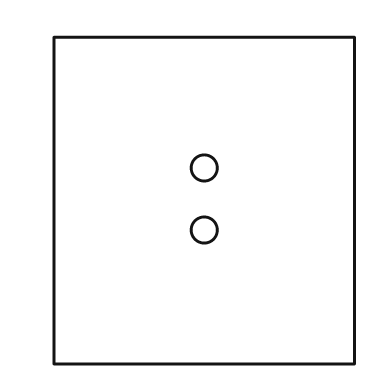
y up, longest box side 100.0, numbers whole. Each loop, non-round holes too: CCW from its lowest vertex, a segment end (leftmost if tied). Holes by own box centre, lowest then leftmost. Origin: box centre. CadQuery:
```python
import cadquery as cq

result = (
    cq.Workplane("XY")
    .moveTo(-46.0, -50.0)
    .lineTo(46.0, -50.0)
    .lineTo(46.0, 50.0)
    .lineTo(-46.0, 50.0)
    .close()
    .moveTo(0.0, -9.0)
    .circle(4.0)
    .moveTo(0.0, 10.0)
    .circle(4.0)
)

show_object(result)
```